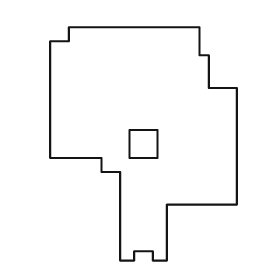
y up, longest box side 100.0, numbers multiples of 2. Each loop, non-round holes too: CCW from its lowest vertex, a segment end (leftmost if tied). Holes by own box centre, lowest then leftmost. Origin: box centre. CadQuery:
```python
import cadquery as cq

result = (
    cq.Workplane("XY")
    .moveTo(-10.0, -50.0)
    .lineTo(-4.0, -50.0)
    .lineTo(-4.0, -46.0)
    .lineTo(4.0, -46.0)
    .lineTo(4.0, -50.0)
    .lineTo(10.0, -50.0)
    .lineTo(10.0, -26.0)
    .lineTo(40.0, -26.0)
    .lineTo(40.0, 24.0)
    .lineTo(28.0, 24.0)
    .lineTo(28.0, 38.0)
    .lineTo(24.0, 38.0)
    .lineTo(24.0, 50.0)
    .lineTo(-32.0, 50.0)
    .lineTo(-32.0, 44.0)
    .lineTo(-40.0, 44.0)
    .lineTo(-40.0, -6.0)
    .lineTo(-18.0, -6.0)
    .lineTo(-18.0, -12.0)
    .lineTo(-10.0, -12.0)
    .close()
    .moveTo(-6.0, -6.0)
    .lineTo(6.0, -6.0)
    .lineTo(6.0, 6.0)
    .lineTo(-6.0, 6.0)
    .close()
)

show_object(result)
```